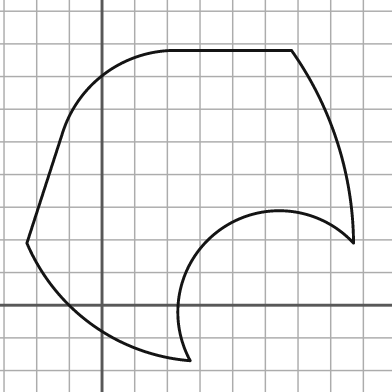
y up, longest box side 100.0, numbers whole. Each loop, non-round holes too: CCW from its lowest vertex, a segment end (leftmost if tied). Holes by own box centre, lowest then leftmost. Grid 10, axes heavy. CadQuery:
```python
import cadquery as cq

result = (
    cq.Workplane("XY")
    .moveTo(27.0, -17.0)
    .threePointArc((36.0, 23.0), (77.0, 19.0))
    .threePointArc((72.0, 50.0), (58.0, 78.0))
    .lineTo(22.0, 78.0)
    .threePointArc((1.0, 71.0), (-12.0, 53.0))
    .lineTo(-23.0, 19.0)
    .threePointArc((-3.0, -6.0), (27.0, -17.0))
    .close()
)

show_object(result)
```